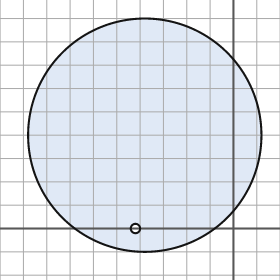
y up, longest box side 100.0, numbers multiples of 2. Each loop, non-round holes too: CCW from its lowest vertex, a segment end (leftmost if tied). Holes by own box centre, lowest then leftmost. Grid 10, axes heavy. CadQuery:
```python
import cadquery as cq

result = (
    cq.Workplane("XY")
    .moveTo(-38.0, 40.0)
    .circle(50.0)
    .moveTo(-42.0, 0.0)
    .circle(2.0)
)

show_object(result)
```